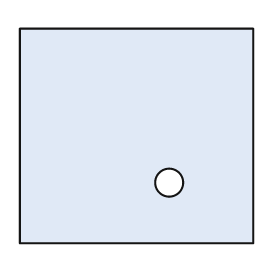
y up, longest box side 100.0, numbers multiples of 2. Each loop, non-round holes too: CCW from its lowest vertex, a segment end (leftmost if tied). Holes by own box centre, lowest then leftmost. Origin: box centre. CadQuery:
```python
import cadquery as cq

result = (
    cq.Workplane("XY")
    .moveTo(-50.0, -46.0)
    .lineTo(50.0, -46.0)
    .lineTo(50.0, 46.0)
    .lineTo(-50.0, 46.0)
    .close()
    .moveTo(14.0, -20.0)
    .circle(6.0)
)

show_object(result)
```